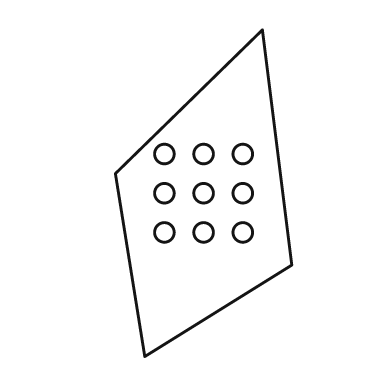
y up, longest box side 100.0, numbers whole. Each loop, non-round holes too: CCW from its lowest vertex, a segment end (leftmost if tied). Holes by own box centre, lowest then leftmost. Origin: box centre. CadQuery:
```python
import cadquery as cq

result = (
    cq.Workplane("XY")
    .moveTo(-18.0, -50.0)
    .lineTo(27.0, -22.0)
    .lineTo(18.0, 50.0)
    .lineTo(-27.0, 6.0)
    .close()
    .moveTo(-12.0, -12.0)
    .circle(3.0)
    .moveTo(0.0, -12.0)
    .circle(3.0)
    .moveTo(12.0, -12.0)
    .circle(3.0)
    .moveTo(-12.0, 0.0)
    .circle(3.0)
    .moveTo(0.0, 0.0)
    .circle(3.0)
    .moveTo(12.0, 0.0)
    .circle(3.0)
    .moveTo(-12.0, 12.0)
    .circle(3.0)
    .moveTo(0.0, 12.0)
    .circle(3.0)
    .moveTo(12.0, 12.0)
    .circle(3.0)
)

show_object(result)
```